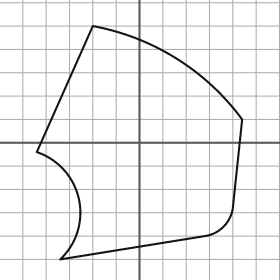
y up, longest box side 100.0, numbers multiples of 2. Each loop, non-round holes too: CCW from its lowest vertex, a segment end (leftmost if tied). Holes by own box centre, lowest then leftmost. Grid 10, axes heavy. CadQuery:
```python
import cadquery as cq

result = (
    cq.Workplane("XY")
    .moveTo(-34.0, -50.0)
    .lineTo(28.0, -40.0)
    .threePointArc((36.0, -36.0), (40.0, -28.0))
    .lineTo(44.0, 10.0)
    .threePointArc((16.0, 36.0), (-20.0, 50.0))
    .lineTo(-44.0, -4.0)
    .threePointArc((-26.0, -24.0), (-34.0, -50.0))
    .close()
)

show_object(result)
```